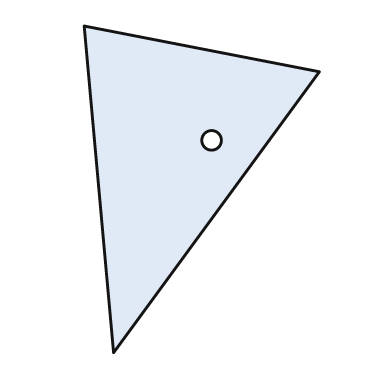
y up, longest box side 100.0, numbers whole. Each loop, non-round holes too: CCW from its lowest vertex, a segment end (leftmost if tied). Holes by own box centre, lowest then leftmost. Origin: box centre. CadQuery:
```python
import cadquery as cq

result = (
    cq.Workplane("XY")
    .moveTo(-27.0, -50.0)
    .lineTo(36.0, 36.0)
    .lineTo(-36.0, 50.0)
    .close()
    .moveTo(3.0, 15.0)
    .circle(3.0)
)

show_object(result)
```